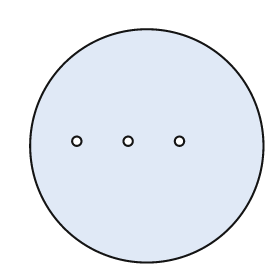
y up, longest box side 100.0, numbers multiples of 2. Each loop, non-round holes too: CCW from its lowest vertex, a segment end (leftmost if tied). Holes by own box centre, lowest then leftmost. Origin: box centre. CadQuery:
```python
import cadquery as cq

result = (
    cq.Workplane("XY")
    .moveTo(0.0, 0.0)
    .circle(50.0)
    .moveTo(-30.0, 2.0)
    .circle(2.0)
    .moveTo(-8.0, 2.0)
    .circle(2.0)
    .moveTo(14.0, 2.0)
    .circle(2.0)
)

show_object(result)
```